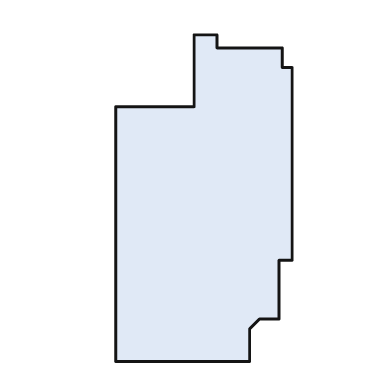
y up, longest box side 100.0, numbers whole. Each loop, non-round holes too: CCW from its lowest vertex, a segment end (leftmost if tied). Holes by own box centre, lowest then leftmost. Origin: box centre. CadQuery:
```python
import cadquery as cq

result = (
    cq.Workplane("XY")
    .moveTo(-27.0, -50.0)
    .lineTo(14.0, -50.0)
    .lineTo(14.0, -40.0)
    .lineTo(17.0, -37.0)
    .lineTo(23.0, -37.0)
    .lineTo(23.0, -19.0)
    .lineTo(27.0, -19.0)
    .lineTo(27.0, 40.0)
    .lineTo(24.0, 40.0)
    .lineTo(24.0, 46.0)
    .lineTo(4.0, 46.0)
    .lineTo(4.0, 50.0)
    .lineTo(-3.0, 50.0)
    .lineTo(-3.0, 28.0)
    .lineTo(-27.0, 28.0)
    .close()
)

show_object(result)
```